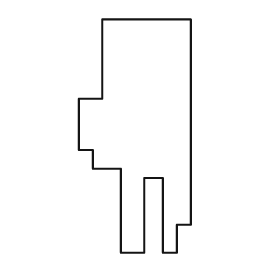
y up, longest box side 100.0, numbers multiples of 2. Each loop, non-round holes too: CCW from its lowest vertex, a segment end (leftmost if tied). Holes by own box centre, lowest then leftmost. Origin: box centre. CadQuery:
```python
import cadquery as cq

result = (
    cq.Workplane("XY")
    .moveTo(-6.0, -50.0)
    .lineTo(4.0, -50.0)
    .lineTo(4.0, -18.0)
    .lineTo(12.0, -18.0)
    .lineTo(12.0, -50.0)
    .lineTo(18.0, -50.0)
    .lineTo(18.0, -38.0)
    .lineTo(24.0, -38.0)
    .lineTo(24.0, 50.0)
    .lineTo(-14.0, 50.0)
    .lineTo(-14.0, 16.0)
    .lineTo(-24.0, 16.0)
    .lineTo(-24.0, -6.0)
    .lineTo(-18.0, -6.0)
    .lineTo(-18.0, -14.0)
    .lineTo(-6.0, -14.0)
    .close()
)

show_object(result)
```